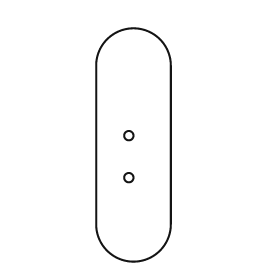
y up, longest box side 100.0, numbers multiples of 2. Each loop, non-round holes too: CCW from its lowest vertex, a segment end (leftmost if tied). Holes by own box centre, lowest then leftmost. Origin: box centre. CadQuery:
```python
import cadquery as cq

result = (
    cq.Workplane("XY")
    .moveTo(-16.0, -34.0)
    .threePointArc((0.0, -50.0), (16.0, -34.0))
    .lineTo(16.0, 34.0)
    .threePointArc((0.0, 50.0), (-16.0, 34.0))
    .close()
    .moveTo(-2.0, -14.0)
    .circle(2.0)
    .moveTo(-2.0, 4.0)
    .circle(2.0)
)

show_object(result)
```